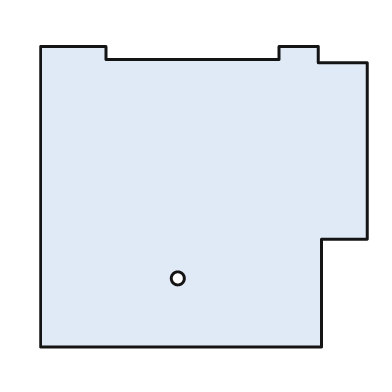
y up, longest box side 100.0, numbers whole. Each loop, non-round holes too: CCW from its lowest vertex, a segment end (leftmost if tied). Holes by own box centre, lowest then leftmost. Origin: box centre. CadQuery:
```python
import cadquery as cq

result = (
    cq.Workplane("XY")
    .moveTo(-50.0, -46.0)
    .lineTo(36.0, -46.0)
    .lineTo(36.0, -13.0)
    .lineTo(50.0, -13.0)
    .lineTo(50.0, 41.0)
    .lineTo(35.0, 41.0)
    .lineTo(35.0, 46.0)
    .lineTo(23.0, 46.0)
    .lineTo(23.0, 42.0)
    .lineTo(-30.0, 42.0)
    .lineTo(-30.0, 46.0)
    .lineTo(-50.0, 46.0)
    .close()
    .moveTo(-8.0, -25.0)
    .circle(2.0)
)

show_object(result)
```